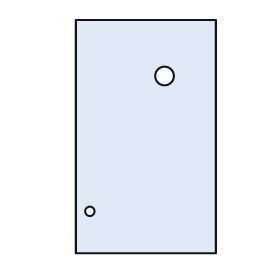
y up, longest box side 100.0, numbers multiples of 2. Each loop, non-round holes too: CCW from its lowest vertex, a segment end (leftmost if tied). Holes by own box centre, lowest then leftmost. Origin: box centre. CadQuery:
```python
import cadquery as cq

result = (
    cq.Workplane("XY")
    .moveTo(-30.0, -50.0)
    .lineTo(30.0, -50.0)
    .lineTo(30.0, 50.0)
    .lineTo(-30.0, 50.0)
    .close()
    .moveTo(-24.0, -32.0)
    .circle(2.0)
    .moveTo(8.0, 26.0)
    .circle(4.0)
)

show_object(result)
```